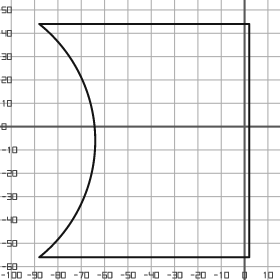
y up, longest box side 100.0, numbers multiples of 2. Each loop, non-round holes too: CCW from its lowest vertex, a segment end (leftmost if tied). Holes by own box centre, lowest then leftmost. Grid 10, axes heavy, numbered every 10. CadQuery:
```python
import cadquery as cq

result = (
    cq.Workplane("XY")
    .moveTo(-88.0, -56.0)
    .lineTo(2.0, -56.0)
    .lineTo(2.0, 44.0)
    .lineTo(-88.0, 44.0)
    .threePointArc((-64.0, -6.0), (-88.0, -56.0))
    .close()
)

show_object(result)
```